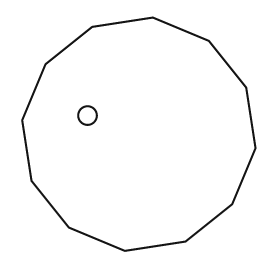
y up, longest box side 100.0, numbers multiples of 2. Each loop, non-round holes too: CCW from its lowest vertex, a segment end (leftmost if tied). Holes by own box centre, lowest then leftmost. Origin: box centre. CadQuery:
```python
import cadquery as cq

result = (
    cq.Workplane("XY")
    .moveTo(-6.0, -50.0)
    .lineTo(20.0, -46.0)
    .lineTo(40.0, -30.0)
    .lineTo(50.0, -6.0)
    .lineTo(46.0, 20.0)
    .lineTo(30.0, 40.0)
    .lineTo(6.0, 50.0)
    .lineTo(-20.0, 46.0)
    .lineTo(-40.0, 30.0)
    .lineTo(-50.0, 6.0)
    .lineTo(-46.0, -20.0)
    .lineTo(-30.0, -40.0)
    .close()
    .moveTo(-22.0, 8.0)
    .circle(4.0)
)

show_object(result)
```